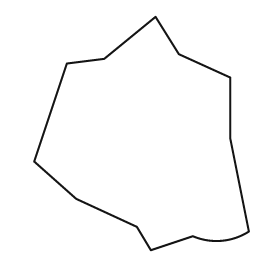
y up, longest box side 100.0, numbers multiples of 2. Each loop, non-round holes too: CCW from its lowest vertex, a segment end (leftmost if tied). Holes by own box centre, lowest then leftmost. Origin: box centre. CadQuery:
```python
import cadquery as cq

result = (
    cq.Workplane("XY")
    .moveTo(4.0, -50.0)
    .lineTo(22.0, -44.0)
    .threePointArc((34.0, -46.0), (46.0, -42.0))
    .lineTo(38.0, -2.0)
    .lineTo(38.0, 24.0)
    .lineTo(16.0, 34.0)
    .lineTo(6.0, 50.0)
    .lineTo(-16.0, 32.0)
    .lineTo(-32.0, 30.0)
    .lineTo(-46.0, -12.0)
    .lineTo(-28.0, -28.0)
    .lineTo(-2.0, -40.0)
    .close()
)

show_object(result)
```